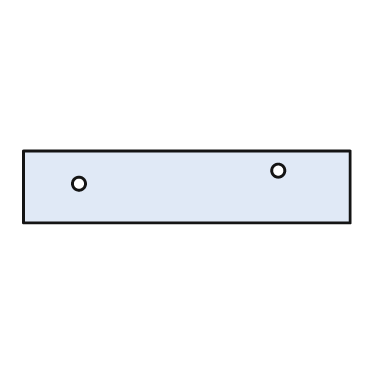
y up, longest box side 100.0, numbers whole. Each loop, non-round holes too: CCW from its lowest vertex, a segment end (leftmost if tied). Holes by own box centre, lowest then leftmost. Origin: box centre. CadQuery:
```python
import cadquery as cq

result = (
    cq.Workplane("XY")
    .moveTo(-50.0, -11.0)
    .lineTo(50.0, -11.0)
    .lineTo(50.0, 11.0)
    .lineTo(-50.0, 11.0)
    .close()
    .moveTo(-33.0, 1.0)
    .circle(2.0)
    .moveTo(28.0, 5.0)
    .circle(2.0)
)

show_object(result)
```